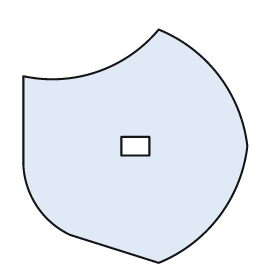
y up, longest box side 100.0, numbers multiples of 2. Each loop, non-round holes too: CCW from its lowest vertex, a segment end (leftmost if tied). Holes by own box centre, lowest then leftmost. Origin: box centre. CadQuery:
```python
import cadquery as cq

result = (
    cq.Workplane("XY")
    .moveTo(10.0, -50.0)
    .threePointArc((36.0, -30.0), (48.0, 0.0))
    .threePointArc((36.0, 30.0), (10.0, 50.0))
    .threePointArc((-16.0, 32.0), (-48.0, 30.0))
    .lineTo(-48.0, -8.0)
    .threePointArc((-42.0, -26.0), (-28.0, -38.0))
    .close()
    .moveTo(-6.0, -4.0)
    .lineTo(6.0, -4.0)
    .lineTo(6.0, 4.0)
    .lineTo(-6.0, 4.0)
    .close()
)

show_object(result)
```